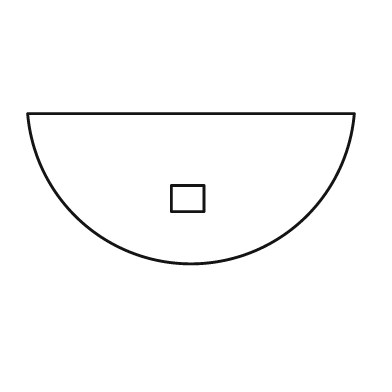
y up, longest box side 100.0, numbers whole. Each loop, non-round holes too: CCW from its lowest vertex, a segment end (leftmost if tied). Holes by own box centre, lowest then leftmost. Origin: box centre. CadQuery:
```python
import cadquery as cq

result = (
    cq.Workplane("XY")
    .moveTo(-50.0, 23.0)
    .threePointArc((0.0, -23.0), (50.0, 23.0))
    .close()
    .moveTo(-6.0, -7.0)
    .lineTo(4.0, -7.0)
    .lineTo(4.0, 1.0)
    .lineTo(-6.0, 1.0)
    .close()
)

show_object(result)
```